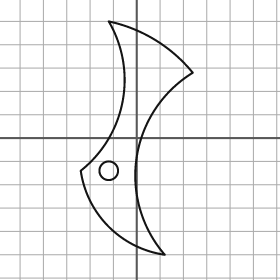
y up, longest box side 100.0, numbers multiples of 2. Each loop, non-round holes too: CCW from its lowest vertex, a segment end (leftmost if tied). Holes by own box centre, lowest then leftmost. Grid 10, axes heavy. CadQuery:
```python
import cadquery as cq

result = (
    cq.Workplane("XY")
    .moveTo(12.0, -50.0)
    .threePointArc((0.0, -8.0), (24.0, 28.0))
    .threePointArc((8.0, 42.0), (-12.0, 50.0))
    .threePointArc((-6.0, 16.0), (-24.0, -14.0))
    .threePointArc((-12.0, -38.0), (12.0, -50.0))
    .close()
    .moveTo(-12.0, -14.0)
    .circle(4.0)
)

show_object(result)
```